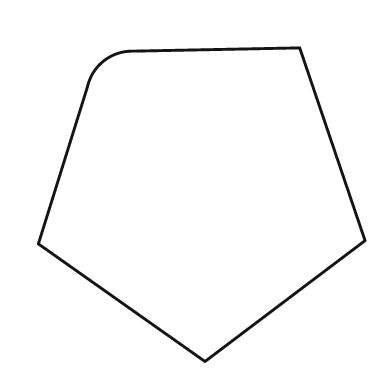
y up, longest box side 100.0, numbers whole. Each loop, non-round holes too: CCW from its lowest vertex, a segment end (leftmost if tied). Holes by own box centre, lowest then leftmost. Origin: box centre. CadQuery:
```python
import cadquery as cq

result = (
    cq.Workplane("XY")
    .moveTo(1.0, -48.0)
    .lineTo(50.0, -11.0)
    .lineTo(30.0, 48.0)
    .lineTo(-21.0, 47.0)
    .threePointArc((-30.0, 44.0), (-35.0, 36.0))
    .lineTo(-50.0, -12.0)
    .close()
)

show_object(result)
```